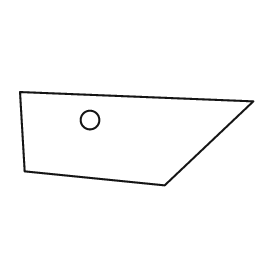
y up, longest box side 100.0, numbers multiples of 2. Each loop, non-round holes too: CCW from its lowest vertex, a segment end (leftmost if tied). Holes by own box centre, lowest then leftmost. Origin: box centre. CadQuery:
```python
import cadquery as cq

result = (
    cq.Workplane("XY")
    .moveTo(12.0, -20.0)
    .lineTo(50.0, 16.0)
    .lineTo(-50.0, 20.0)
    .lineTo(-48.0, -14.0)
    .close()
    .moveTo(-20.0, 8.0)
    .circle(4.0)
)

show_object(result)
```